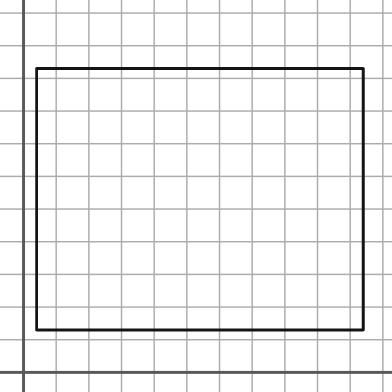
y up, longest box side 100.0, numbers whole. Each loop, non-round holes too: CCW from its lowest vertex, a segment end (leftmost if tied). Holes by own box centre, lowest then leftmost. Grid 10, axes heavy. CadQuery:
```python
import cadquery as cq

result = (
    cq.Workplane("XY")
    .moveTo(4.0, 13.0)
    .lineTo(104.0, 13.0)
    .lineTo(104.0, 93.0)
    .lineTo(4.0, 93.0)
    .close()
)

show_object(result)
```